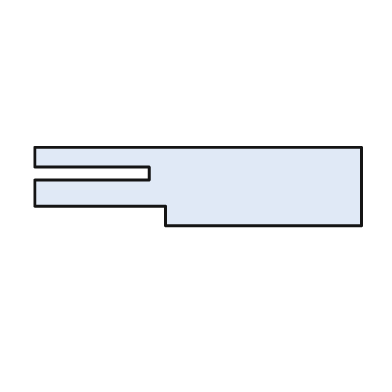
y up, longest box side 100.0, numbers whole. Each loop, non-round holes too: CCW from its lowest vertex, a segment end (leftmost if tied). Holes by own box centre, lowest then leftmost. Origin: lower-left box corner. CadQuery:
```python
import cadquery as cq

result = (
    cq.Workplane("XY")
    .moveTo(40.0, 0.0)
    .lineTo(100.0, 0.0)
    .lineTo(100.0, 24.0)
    .lineTo(0.0, 24.0)
    .lineTo(0.0, 18.0)
    .lineTo(35.0, 18.0)
    .lineTo(35.0, 14.0)
    .lineTo(0.0, 14.0)
    .lineTo(0.0, 6.0)
    .lineTo(40.0, 6.0)
    .close()
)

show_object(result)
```